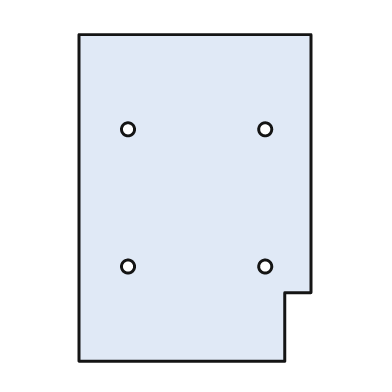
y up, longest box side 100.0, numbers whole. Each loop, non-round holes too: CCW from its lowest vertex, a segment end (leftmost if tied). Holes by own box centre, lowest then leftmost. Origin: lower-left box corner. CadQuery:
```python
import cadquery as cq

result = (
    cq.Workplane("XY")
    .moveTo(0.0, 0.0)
    .lineTo(63.0, 0.0)
    .lineTo(63.0, 21.0)
    .lineTo(71.0, 21.0)
    .lineTo(71.0, 100.0)
    .lineTo(0.0, 100.0)
    .close()
    .moveTo(15.0, 29.0)
    .circle(2.0)
    .moveTo(57.0, 29.0)
    .circle(2.0)
    .moveTo(15.0, 71.0)
    .circle(2.0)
    .moveTo(57.0, 71.0)
    .circle(2.0)
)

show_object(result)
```